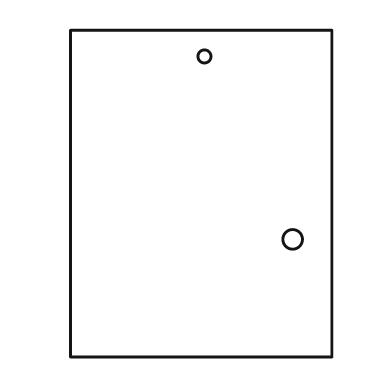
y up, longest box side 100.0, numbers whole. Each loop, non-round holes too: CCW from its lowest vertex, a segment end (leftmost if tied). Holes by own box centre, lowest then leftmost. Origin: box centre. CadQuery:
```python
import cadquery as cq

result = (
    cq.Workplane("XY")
    .moveTo(-40.0, -50.0)
    .lineTo(40.0, -50.0)
    .lineTo(40.0, 50.0)
    .lineTo(-40.0, 50.0)
    .close()
    .moveTo(28.0, -14.0)
    .circle(3.0)
    .moveTo(1.0, 42.0)
    .circle(2.0)
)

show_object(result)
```